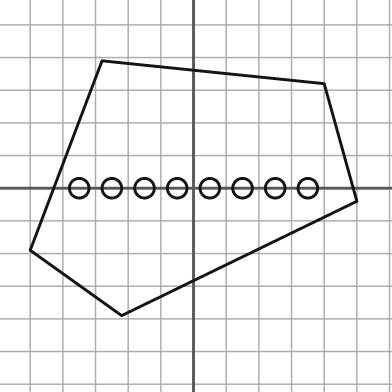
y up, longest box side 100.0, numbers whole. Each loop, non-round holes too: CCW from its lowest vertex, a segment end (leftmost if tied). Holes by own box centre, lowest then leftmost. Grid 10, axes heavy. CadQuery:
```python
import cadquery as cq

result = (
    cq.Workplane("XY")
    .moveTo(-22.0, -39.0)
    .lineTo(50.0, -4.0)
    .lineTo(40.0, 32.0)
    .lineTo(-28.0, 39.0)
    .lineTo(-50.0, -19.0)
    .close()
    .moveTo(-35.0, 0.0)
    .circle(3.0)
    .moveTo(-25.0, 0.0)
    .circle(3.0)
    .moveTo(-15.0, 0.0)
    .circle(3.0)
    .moveTo(-5.0, 0.0)
    .circle(3.0)
    .moveTo(5.0, 0.0)
    .circle(3.0)
    .moveTo(15.0, 0.0)
    .circle(3.0)
    .moveTo(25.0, 0.0)
    .circle(3.0)
    .moveTo(35.0, 0.0)
    .circle(3.0)
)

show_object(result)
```